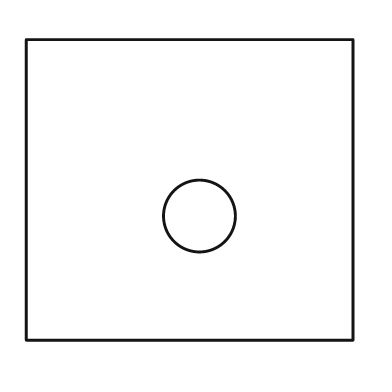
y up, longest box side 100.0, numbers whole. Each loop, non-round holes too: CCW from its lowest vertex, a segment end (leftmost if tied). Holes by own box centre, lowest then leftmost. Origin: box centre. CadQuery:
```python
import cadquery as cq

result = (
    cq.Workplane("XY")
    .moveTo(-50.0, -46.0)
    .lineTo(50.0, -46.0)
    .lineTo(50.0, 46.0)
    .lineTo(-50.0, 46.0)
    .close()
    .moveTo(3.0, -8.0)
    .circle(11.0)
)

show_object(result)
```